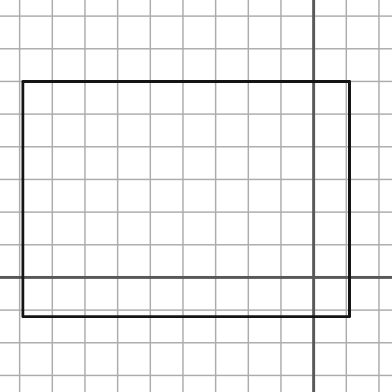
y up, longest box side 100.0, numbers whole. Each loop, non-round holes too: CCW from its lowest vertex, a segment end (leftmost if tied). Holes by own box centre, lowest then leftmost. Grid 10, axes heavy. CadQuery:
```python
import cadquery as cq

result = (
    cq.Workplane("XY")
    .moveTo(-89.0, -12.0)
    .lineTo(11.0, -12.0)
    .lineTo(11.0, 60.0)
    .lineTo(-89.0, 60.0)
    .close()
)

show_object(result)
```